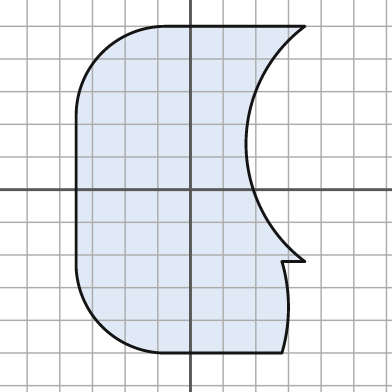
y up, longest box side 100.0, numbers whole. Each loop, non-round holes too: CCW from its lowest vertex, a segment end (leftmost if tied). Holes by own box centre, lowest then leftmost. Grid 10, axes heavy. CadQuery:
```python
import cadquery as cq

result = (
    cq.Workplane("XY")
    .moveTo(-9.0, -50.0)
    .lineTo(28.0, -50.0)
    .threePointArc((30.0, -36.0), (28.0, -22.0))
    .lineTo(35.0, -22.0)
    .threePointArc((17.0, 14.0), (35.0, 50.0))
    .lineTo(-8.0, 50.0)
    .threePointArc((-27.0, 42.0), (-35.0, 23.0))
    .lineTo(-35.0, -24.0)
    .threePointArc((-27.0, -42.0), (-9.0, -50.0))
    .close()
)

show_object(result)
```